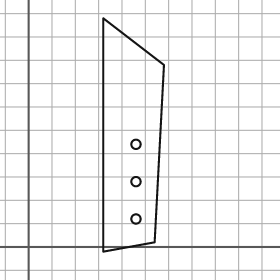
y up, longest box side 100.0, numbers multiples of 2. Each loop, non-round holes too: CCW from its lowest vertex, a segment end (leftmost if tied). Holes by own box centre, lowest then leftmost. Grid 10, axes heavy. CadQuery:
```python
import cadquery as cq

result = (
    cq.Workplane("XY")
    .moveTo(32.0, -2.0)
    .lineTo(54.0, 2.0)
    .lineTo(58.0, 78.0)
    .lineTo(32.0, 98.0)
    .close()
    .moveTo(46.0, 12.0)
    .circle(2.0)
    .moveTo(46.0, 28.0)
    .circle(2.0)
    .moveTo(46.0, 44.0)
    .circle(2.0)
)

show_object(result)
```